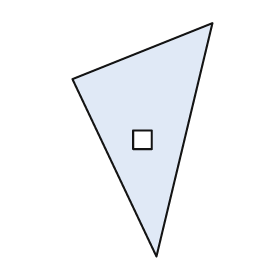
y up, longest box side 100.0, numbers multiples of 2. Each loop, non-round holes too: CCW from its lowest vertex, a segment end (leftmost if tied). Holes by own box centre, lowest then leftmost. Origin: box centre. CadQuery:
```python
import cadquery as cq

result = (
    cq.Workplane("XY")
    .moveTo(6.0, -50.0)
    .lineTo(30.0, 50.0)
    .lineTo(-30.0, 26.0)
    .close()
    .moveTo(-4.0, -4.0)
    .lineTo(4.0, -4.0)
    .lineTo(4.0, 4.0)
    .lineTo(-4.0, 4.0)
    .close()
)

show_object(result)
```